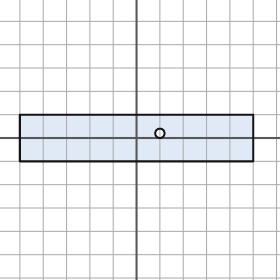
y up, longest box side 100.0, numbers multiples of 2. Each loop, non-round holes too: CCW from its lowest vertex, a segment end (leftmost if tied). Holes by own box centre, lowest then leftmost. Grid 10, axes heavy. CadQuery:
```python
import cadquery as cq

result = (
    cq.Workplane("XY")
    .moveTo(-50.0, -10.0)
    .lineTo(50.0, -10.0)
    .lineTo(50.0, 10.0)
    .lineTo(-50.0, 10.0)
    .close()
    .moveTo(10.0, 2.0)
    .circle(2.0)
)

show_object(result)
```